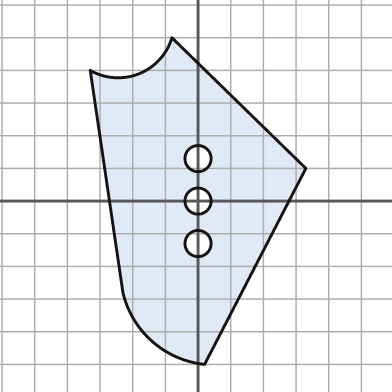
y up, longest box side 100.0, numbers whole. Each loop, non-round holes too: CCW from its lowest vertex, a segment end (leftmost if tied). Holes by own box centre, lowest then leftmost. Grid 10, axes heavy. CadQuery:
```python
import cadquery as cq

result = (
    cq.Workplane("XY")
    .moveTo(2.0, -50.0)
    .lineTo(33.0, 10.0)
    .lineTo(-8.0, 50.0)
    .threePointArc((-18.0, 39.0), (-33.0, 40.0))
    .lineTo(-23.0, -28.0)
    .threePointArc((-14.0, -43.0), (2.0, -50.0))
    .close()
    .moveTo(0.0, -13.0)
    .circle(4.0)
    .moveTo(0.0, 0.0)
    .circle(4.0)
    .moveTo(0.0, 13.0)
    .circle(4.0)
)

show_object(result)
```